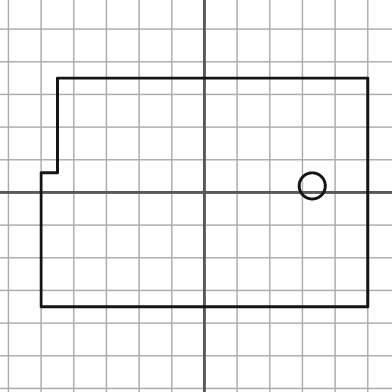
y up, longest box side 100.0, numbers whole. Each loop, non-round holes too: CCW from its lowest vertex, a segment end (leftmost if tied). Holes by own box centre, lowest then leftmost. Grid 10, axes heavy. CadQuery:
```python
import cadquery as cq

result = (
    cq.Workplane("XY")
    .moveTo(-50.0, -35.0)
    .lineTo(50.0, -35.0)
    .lineTo(50.0, 35.0)
    .lineTo(-45.0, 35.0)
    .lineTo(-45.0, 6.0)
    .lineTo(-50.0, 6.0)
    .close()
    .moveTo(33.0, 2.0)
    .circle(4.0)
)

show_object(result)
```